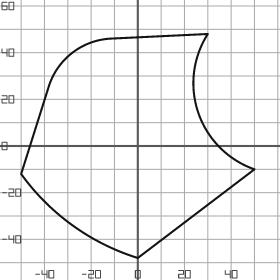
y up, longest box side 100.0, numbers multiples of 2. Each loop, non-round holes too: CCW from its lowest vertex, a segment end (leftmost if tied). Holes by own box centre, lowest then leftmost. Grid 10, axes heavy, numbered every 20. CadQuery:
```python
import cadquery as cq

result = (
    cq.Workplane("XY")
    .moveTo(0.0, -48.0)
    .lineTo(50.0, -10.0)
    .threePointArc((26.0, 14.0), (30.0, 48.0))
    .lineTo(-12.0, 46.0)
    .threePointArc((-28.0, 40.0), (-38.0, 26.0))
    .lineTo(-50.0, -12.0)
    .threePointArc((-28.0, -34.0), (0.0, -48.0))
    .close()
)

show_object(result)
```